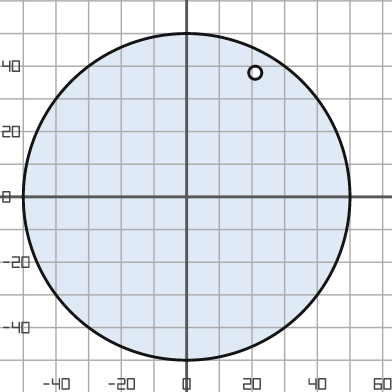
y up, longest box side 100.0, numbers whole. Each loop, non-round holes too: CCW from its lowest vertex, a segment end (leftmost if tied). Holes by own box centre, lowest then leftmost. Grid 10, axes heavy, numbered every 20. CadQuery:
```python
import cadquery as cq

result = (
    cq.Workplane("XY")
    .moveTo(0.0, 0.0)
    .circle(50.0)
    .moveTo(21.0, 38.0)
    .circle(2.0)
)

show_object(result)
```